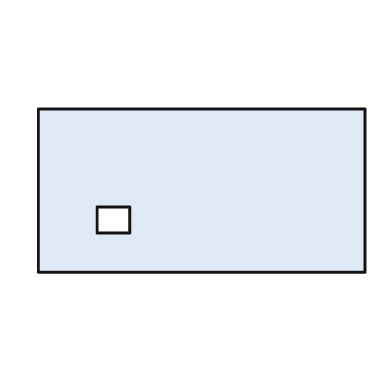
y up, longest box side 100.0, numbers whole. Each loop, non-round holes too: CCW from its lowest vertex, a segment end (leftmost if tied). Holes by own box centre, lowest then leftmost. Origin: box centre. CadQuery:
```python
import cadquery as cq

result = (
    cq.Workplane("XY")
    .moveTo(-50.0, -25.0)
    .lineTo(50.0, -25.0)
    .lineTo(50.0, 25.0)
    .lineTo(-50.0, 25.0)
    .close()
    .moveTo(-32.0, -13.0)
    .lineTo(-22.0, -13.0)
    .lineTo(-22.0, -5.0)
    .lineTo(-32.0, -5.0)
    .close()
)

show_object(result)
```